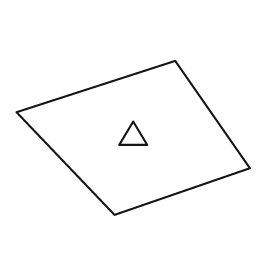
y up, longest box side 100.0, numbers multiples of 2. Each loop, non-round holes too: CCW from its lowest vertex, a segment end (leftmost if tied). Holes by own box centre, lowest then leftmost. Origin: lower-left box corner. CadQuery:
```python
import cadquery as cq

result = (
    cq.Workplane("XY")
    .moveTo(42.0, 0.0)
    .lineTo(100.0, 20.0)
    .lineTo(68.0, 66.0)
    .lineTo(0.0, 44.0)
    .close()
    .moveTo(44.0, 30.0)
    .lineTo(56.0, 30.0)
    .lineTo(50.0, 40.0)
    .close()
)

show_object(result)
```